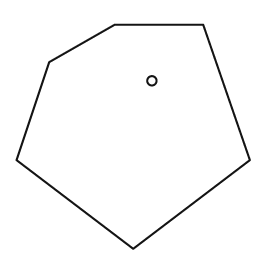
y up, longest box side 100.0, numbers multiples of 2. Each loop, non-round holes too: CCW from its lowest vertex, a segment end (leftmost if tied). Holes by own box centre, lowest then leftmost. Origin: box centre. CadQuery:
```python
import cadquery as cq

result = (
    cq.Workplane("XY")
    .moveTo(0.0, -48.0)
    .lineTo(50.0, -10.0)
    .lineTo(30.0, 48.0)
    .lineTo(-8.0, 48.0)
    .lineTo(-36.0, 32.0)
    .lineTo(-50.0, -10.0)
    .close()
    .moveTo(8.0, 24.0)
    .circle(2.0)
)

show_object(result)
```